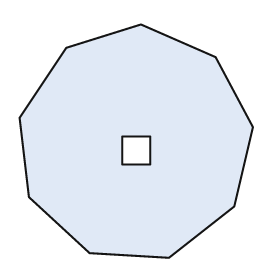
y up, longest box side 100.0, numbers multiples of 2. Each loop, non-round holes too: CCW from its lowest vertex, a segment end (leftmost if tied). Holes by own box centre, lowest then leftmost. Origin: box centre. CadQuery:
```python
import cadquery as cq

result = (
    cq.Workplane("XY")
    .moveTo(14.0, -50.0)
    .lineTo(42.0, -28.0)
    .lineTo(50.0, 6.0)
    .lineTo(34.0, 36.0)
    .lineTo(2.0, 50.0)
    .lineTo(-30.0, 40.0)
    .lineTo(-50.0, 10.0)
    .lineTo(-46.0, -24.0)
    .lineTo(-20.0, -48.0)
    .close()
    .moveTo(-6.0, -10.0)
    .lineTo(6.0, -10.0)
    .lineTo(6.0, 2.0)
    .lineTo(-6.0, 2.0)
    .close()
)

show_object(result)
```